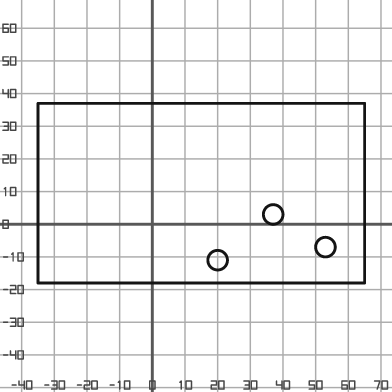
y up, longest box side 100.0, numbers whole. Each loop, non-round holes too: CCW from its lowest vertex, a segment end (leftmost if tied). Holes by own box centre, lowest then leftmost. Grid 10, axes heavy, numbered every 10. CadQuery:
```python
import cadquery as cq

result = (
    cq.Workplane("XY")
    .moveTo(-35.0, -18.0)
    .lineTo(65.0, -18.0)
    .lineTo(65.0, 37.0)
    .lineTo(-35.0, 37.0)
    .close()
    .moveTo(20.0, -11.0)
    .circle(3.0)
    .moveTo(53.0, -7.0)
    .circle(3.0)
    .moveTo(37.0, 3.0)
    .circle(3.0)
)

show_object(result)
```